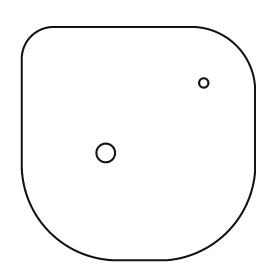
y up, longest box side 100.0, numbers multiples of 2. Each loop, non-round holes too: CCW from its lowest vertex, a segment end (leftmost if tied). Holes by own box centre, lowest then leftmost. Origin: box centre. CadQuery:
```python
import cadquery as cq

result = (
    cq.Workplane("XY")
    .moveTo(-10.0, -50.0)
    .lineTo(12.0, -50.0)
    .threePointArc((38.0, -38.0), (50.0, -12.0))
    .lineTo(50.0, 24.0)
    .threePointArc((42.0, 42.0), (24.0, 50.0))
    .lineTo(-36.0, 50.0)
    .threePointArc((-46.0, 46.0), (-50.0, 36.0))
    .lineTo(-50.0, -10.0)
    .threePointArc((-38.0, -38.0), (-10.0, -50.0))
    .close()
    .moveTo(-14.0, -4.0)
    .circle(4.0)
    .moveTo(28.0, 26.0)
    .circle(2.0)
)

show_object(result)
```